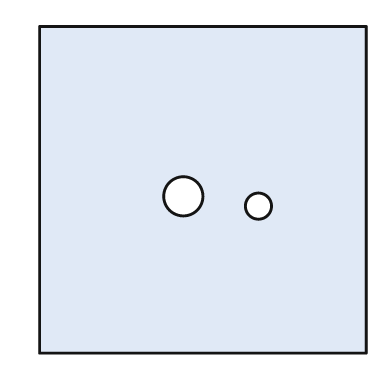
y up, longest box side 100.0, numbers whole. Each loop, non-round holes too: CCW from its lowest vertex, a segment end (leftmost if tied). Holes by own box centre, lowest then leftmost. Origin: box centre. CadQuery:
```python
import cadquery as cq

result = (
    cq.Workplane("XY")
    .moveTo(-50.0, -50.0)
    .lineTo(50.0, -50.0)
    .lineTo(50.0, 50.0)
    .lineTo(-50.0, 50.0)
    .close()
    .moveTo(17.0, -5.0)
    .circle(4.0)
    .moveTo(-6.0, -2.0)
    .circle(6.0)
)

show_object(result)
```